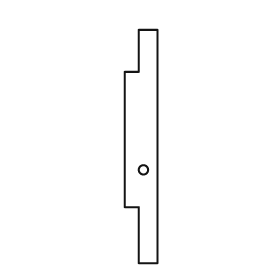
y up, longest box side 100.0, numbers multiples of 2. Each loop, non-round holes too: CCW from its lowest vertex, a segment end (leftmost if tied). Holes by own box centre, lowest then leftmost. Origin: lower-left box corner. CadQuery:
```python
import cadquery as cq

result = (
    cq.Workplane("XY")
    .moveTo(6.0, 0.0)
    .lineTo(14.0, 0.0)
    .lineTo(14.0, 100.0)
    .lineTo(6.0, 100.0)
    .lineTo(6.0, 82.0)
    .lineTo(0.0, 82.0)
    .lineTo(0.0, 24.0)
    .lineTo(6.0, 24.0)
    .close()
    .moveTo(8.0, 40.0)
    .circle(2.0)
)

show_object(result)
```